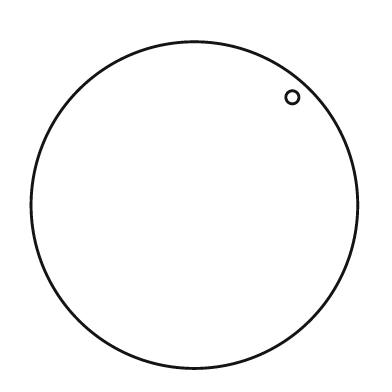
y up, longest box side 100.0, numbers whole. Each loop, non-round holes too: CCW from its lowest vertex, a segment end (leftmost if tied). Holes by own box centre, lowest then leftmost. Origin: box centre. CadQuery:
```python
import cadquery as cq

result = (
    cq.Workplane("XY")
    .moveTo(0.0, 0.0)
    .circle(50.0)
    .moveTo(30.0, 33.0)
    .circle(2.0)
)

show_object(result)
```